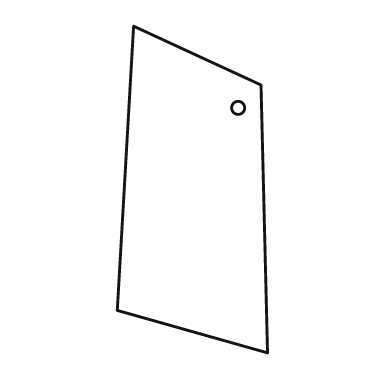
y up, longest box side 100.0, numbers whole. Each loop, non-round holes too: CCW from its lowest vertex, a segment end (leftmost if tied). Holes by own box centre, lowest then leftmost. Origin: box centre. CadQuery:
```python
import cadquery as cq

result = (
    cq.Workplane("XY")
    .moveTo(23.0, -50.0)
    .lineTo(21.0, 32.0)
    .lineTo(-18.0, 50.0)
    .lineTo(-23.0, -37.0)
    .close()
    .moveTo(14.0, 25.0)
    .circle(2.0)
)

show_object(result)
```